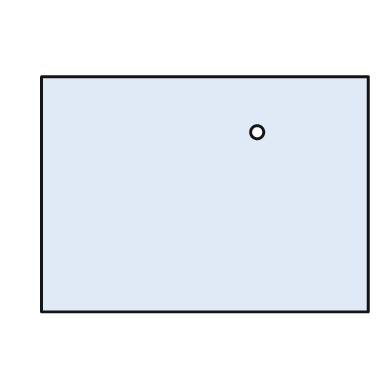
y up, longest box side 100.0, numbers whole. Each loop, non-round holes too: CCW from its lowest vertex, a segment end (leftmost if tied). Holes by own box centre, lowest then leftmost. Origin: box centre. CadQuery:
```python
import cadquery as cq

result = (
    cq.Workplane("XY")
    .moveTo(-50.0, -36.0)
    .lineTo(50.0, -36.0)
    .lineTo(50.0, 36.0)
    .lineTo(-50.0, 36.0)
    .close()
    .moveTo(16.0, 19.0)
    .circle(2.0)
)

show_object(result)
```